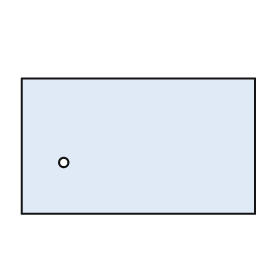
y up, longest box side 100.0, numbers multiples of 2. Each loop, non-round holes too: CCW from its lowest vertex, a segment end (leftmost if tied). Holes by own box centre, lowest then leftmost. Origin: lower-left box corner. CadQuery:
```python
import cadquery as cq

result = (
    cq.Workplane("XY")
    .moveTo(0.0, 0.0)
    .lineTo(100.0, 0.0)
    .lineTo(100.0, 58.0)
    .lineTo(0.0, 58.0)
    .close()
    .moveTo(18.0, 22.0)
    .circle(2.0)
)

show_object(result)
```